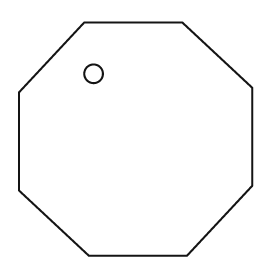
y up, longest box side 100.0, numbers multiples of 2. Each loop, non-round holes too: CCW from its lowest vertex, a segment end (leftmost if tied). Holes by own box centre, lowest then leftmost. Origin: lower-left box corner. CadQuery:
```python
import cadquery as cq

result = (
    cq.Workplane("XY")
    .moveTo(30.0, 0.0)
    .lineTo(72.0, 0.0)
    .lineTo(100.0, 30.0)
    .lineTo(100.0, 72.0)
    .lineTo(70.0, 100.0)
    .lineTo(28.0, 100.0)
    .lineTo(0.0, 70.0)
    .lineTo(0.0, 28.0)
    .close()
    .moveTo(32.0, 78.0)
    .circle(4.0)
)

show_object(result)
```